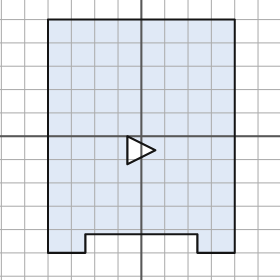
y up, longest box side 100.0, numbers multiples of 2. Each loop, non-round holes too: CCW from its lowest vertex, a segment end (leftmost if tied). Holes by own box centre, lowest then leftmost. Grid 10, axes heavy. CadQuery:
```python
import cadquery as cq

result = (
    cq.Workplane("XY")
    .moveTo(-40.0, -50.0)
    .lineTo(-24.0, -50.0)
    .lineTo(-24.0, -42.0)
    .lineTo(24.0, -42.0)
    .lineTo(24.0, -50.0)
    .lineTo(40.0, -50.0)
    .lineTo(40.0, 50.0)
    .lineTo(-40.0, 50.0)
    .close()
    .moveTo(-6.0, -12.0)
    .lineTo(6.0, -6.0)
    .lineTo(-6.0, 0.0)
    .close()
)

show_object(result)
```